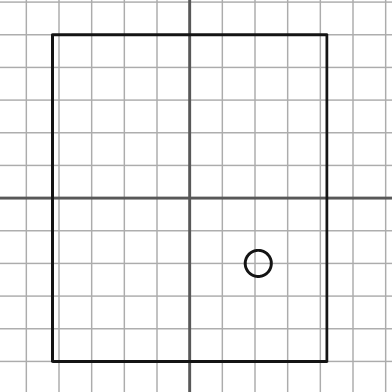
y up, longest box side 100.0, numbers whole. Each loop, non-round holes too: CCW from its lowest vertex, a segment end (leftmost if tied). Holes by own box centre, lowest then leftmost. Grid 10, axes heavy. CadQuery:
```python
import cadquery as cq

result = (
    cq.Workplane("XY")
    .moveTo(-42.0, -50.0)
    .lineTo(42.0, -50.0)
    .lineTo(42.0, 50.0)
    .lineTo(-42.0, 50.0)
    .close()
    .moveTo(21.0, -20.0)
    .circle(4.0)
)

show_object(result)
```